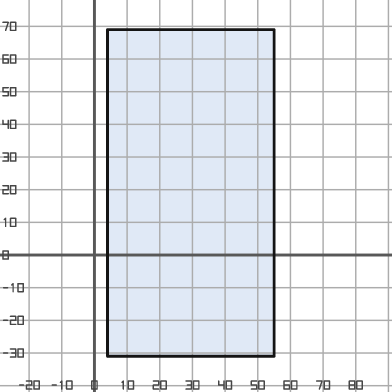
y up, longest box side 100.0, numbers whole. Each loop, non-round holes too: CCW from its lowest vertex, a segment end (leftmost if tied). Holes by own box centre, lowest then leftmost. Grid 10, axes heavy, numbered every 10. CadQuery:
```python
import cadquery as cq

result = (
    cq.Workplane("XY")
    .moveTo(4.0, -31.0)
    .lineTo(55.0, -31.0)
    .lineTo(55.0, 69.0)
    .lineTo(4.0, 69.0)
    .close()
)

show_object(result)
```